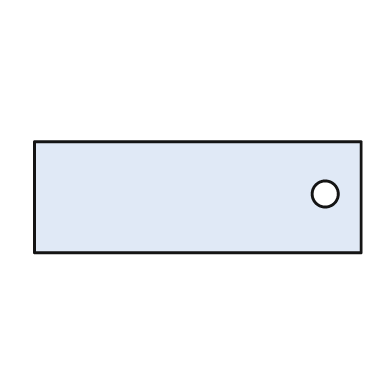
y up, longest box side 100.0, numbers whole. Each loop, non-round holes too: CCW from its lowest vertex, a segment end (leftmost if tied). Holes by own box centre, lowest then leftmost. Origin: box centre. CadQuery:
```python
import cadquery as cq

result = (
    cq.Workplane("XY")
    .moveTo(-50.0, -17.0)
    .lineTo(50.0, -17.0)
    .lineTo(50.0, 17.0)
    .lineTo(-50.0, 17.0)
    .close()
    .moveTo(39.0, 1.0)
    .circle(4.0)
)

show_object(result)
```